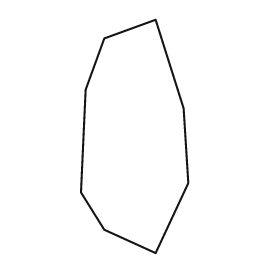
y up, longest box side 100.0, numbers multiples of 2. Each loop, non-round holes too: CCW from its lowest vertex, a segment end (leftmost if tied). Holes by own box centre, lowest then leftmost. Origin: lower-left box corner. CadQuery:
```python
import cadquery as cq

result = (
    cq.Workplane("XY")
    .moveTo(32.0, 0.0)
    .lineTo(46.0, 30.0)
    .lineTo(44.0, 62.0)
    .lineTo(32.0, 100.0)
    .lineTo(10.0, 92.0)
    .lineTo(2.0, 70.0)
    .lineTo(0.0, 26.0)
    .lineTo(10.0, 10.0)
    .close()
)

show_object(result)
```